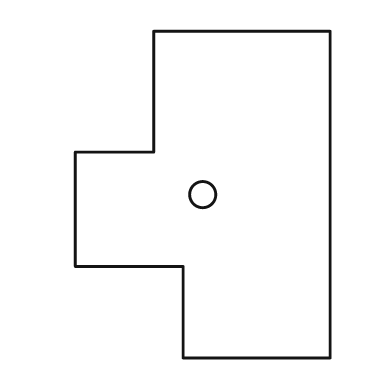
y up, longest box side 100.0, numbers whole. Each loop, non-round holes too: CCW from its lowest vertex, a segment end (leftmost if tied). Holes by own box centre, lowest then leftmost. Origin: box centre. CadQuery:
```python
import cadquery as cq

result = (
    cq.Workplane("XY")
    .moveTo(-6.0, -50.0)
    .lineTo(39.0, -50.0)
    .lineTo(39.0, 50.0)
    .lineTo(-15.0, 50.0)
    .lineTo(-15.0, 13.0)
    .lineTo(-39.0, 13.0)
    .lineTo(-39.0, -22.0)
    .lineTo(-6.0, -22.0)
    .close()
    .moveTo(0.0, 0.0)
    .circle(4.0)
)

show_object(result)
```